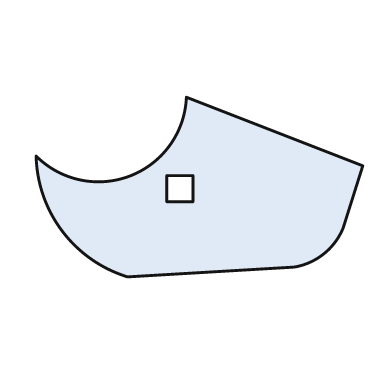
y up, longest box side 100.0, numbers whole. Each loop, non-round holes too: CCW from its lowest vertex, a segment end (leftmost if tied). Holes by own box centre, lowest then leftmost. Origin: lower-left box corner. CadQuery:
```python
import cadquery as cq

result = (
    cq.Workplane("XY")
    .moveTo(28.0, 0.0)
    .lineTo(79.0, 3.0)
    .threePointArc((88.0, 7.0), (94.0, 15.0))
    .lineTo(100.0, 34.0)
    .lineTo(46.0, 55.0)
    .threePointArc((29.0, 31.0), (0.0, 37.0))
    .threePointArc((8.0, 14.0), (28.0, 0.0))
    .close()
    .moveTo(40.0, 23.0)
    .lineTo(48.0, 23.0)
    .lineTo(48.0, 31.0)
    .lineTo(40.0, 31.0)
    .close()
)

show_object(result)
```